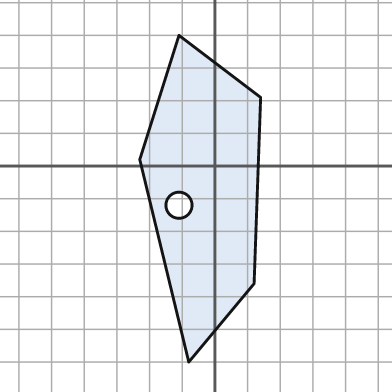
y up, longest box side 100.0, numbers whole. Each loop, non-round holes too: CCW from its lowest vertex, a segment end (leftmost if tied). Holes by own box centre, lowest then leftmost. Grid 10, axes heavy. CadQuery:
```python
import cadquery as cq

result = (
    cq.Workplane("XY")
    .moveTo(-8.0, -60.0)
    .lineTo(12.0, -36.0)
    .lineTo(14.0, 21.0)
    .lineTo(-11.0, 40.0)
    .lineTo(-23.0, 2.0)
    .close()
    .moveTo(-11.0, -12.0)
    .circle(4.0)
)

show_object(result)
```